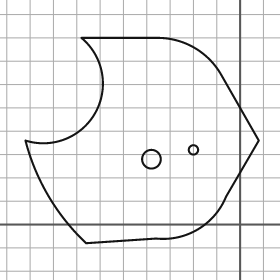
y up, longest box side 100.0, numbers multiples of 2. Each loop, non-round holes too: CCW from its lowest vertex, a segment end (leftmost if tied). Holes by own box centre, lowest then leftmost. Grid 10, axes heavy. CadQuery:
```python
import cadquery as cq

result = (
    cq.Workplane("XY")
    .moveTo(-66.0, -8.0)
    .lineTo(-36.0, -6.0)
    .threePointArc((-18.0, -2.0), (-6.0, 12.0))
    .lineTo(8.0, 36.0)
    .lineTo(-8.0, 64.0)
    .threePointArc((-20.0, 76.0), (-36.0, 80.0))
    .lineTo(-68.0, 80.0)
    .threePointArc((-62.0, 48.0), (-92.0, 36.0))
    .threePointArc((-82.0, 12.0), (-66.0, -8.0))
    .close()
    .moveTo(-38.0, 28.0)
    .circle(4.0)
    .moveTo(-20.0, 32.0)
    .circle(2.0)
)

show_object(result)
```